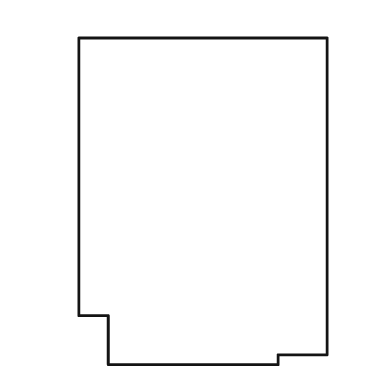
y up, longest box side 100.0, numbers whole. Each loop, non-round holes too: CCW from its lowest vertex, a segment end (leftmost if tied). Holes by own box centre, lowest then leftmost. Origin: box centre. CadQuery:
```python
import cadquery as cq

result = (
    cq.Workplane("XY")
    .moveTo(-29.0, -50.0)
    .lineTo(23.0, -50.0)
    .lineTo(23.0, -47.0)
    .lineTo(38.0, -47.0)
    .lineTo(38.0, 50.0)
    .lineTo(-38.0, 50.0)
    .lineTo(-38.0, -35.0)
    .lineTo(-29.0, -35.0)
    .close()
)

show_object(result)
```